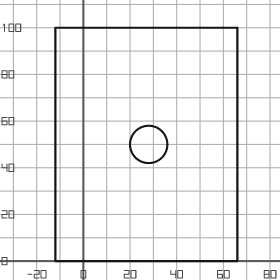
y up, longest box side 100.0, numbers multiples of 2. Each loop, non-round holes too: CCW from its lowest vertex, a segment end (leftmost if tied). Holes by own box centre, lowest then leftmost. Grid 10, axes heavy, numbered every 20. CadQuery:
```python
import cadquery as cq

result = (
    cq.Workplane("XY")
    .moveTo(-12.0, 0.0)
    .lineTo(66.0, 0.0)
    .lineTo(66.0, 100.0)
    .lineTo(-12.0, 100.0)
    .close()
    .moveTo(28.0, 50.0)
    .circle(8.0)
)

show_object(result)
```